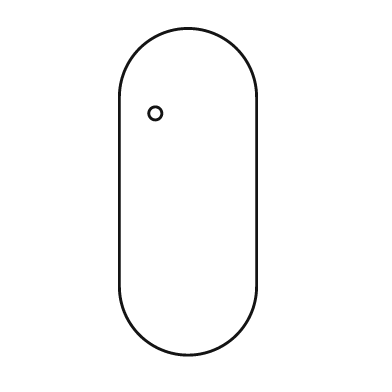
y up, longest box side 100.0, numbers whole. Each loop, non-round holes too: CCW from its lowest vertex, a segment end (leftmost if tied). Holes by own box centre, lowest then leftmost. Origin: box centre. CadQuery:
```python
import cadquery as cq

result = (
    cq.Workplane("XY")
    .moveTo(-21.0, -29.0)
    .threePointArc((0.0, -50.0), (21.0, -29.0))
    .lineTo(21.0, 29.0)
    .threePointArc((0.0, 50.0), (-21.0, 29.0))
    .close()
    .moveTo(-10.0, 24.0)
    .circle(2.0)
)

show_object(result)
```